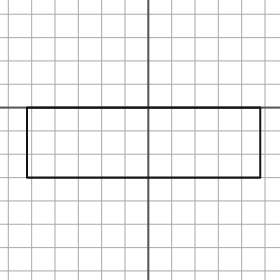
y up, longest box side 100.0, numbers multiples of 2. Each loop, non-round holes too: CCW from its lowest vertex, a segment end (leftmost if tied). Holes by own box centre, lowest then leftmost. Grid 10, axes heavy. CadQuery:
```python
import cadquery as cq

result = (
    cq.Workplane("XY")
    .moveTo(-52.0, -30.0)
    .lineTo(48.0, -30.0)
    .lineTo(48.0, 0.0)
    .lineTo(-52.0, 0.0)
    .close()
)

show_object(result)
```